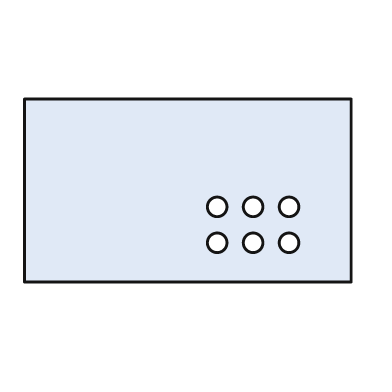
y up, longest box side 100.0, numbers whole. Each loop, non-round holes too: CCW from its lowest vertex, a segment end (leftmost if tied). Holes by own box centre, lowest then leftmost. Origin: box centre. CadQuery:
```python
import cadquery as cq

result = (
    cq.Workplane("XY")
    .moveTo(-50.0, -28.0)
    .lineTo(50.0, -28.0)
    .lineTo(50.0, 28.0)
    .lineTo(-50.0, 28.0)
    .close()
    .moveTo(9.0, -16.0)
    .circle(3.0)
    .moveTo(20.0, -16.0)
    .circle(3.0)
    .moveTo(31.0, -16.0)
    .circle(3.0)
    .moveTo(9.0, -5.0)
    .circle(3.0)
    .moveTo(20.0, -5.0)
    .circle(3.0)
    .moveTo(31.0, -5.0)
    .circle(3.0)
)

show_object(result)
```